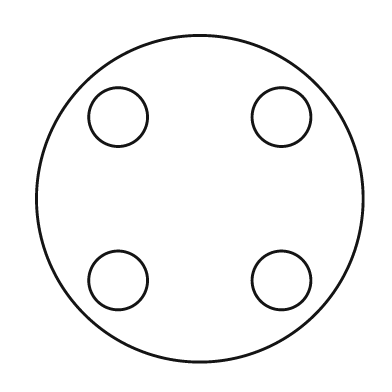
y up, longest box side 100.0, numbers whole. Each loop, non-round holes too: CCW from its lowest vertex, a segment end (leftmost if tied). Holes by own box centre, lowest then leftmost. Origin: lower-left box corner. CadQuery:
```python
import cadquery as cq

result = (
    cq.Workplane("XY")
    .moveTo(50.0, 50.0)
    .circle(50.0)
    .moveTo(25.0, 25.0)
    .circle(9.0)
    .moveTo(75.0, 25.0)
    .circle(9.0)
    .moveTo(25.0, 75.0)
    .circle(9.0)
    .moveTo(75.0, 75.0)
    .circle(9.0)
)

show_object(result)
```